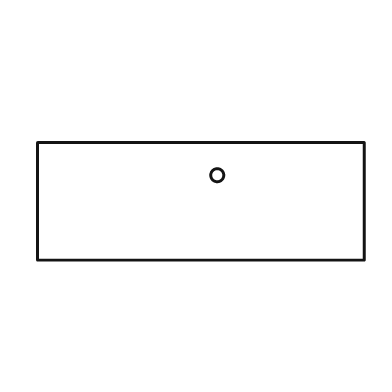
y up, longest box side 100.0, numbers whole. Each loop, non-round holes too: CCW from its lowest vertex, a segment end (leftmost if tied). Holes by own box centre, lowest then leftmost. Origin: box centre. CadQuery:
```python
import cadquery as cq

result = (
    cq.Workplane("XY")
    .moveTo(-50.0, -18.0)
    .lineTo(50.0, -18.0)
    .lineTo(50.0, 18.0)
    .lineTo(-50.0, 18.0)
    .close()
    .moveTo(5.0, 8.0)
    .circle(2.0)
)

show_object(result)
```